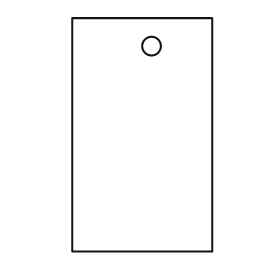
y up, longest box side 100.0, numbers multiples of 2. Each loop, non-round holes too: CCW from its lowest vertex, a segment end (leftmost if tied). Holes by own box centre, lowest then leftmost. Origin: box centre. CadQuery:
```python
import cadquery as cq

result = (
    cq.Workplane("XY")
    .moveTo(-30.0, -50.0)
    .lineTo(30.0, -50.0)
    .lineTo(30.0, 50.0)
    .lineTo(-30.0, 50.0)
    .close()
    .moveTo(4.0, 38.0)
    .circle(4.0)
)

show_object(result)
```